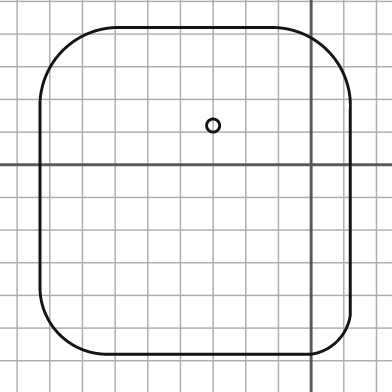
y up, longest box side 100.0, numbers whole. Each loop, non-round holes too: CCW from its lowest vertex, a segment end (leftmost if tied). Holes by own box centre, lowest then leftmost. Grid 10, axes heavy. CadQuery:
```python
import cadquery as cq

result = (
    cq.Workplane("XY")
    .moveTo(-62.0, -58.0)
    .lineTo(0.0, -58.0)
    .threePointArc((8.0, -54.0), (12.0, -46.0))
    .lineTo(12.0, 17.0)
    .threePointArc((5.0, 35.0), (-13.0, 42.0))
    .lineTo(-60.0, 42.0)
    .threePointArc((-76.0, 35.0), (-83.0, 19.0))
    .lineTo(-83.0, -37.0)
    .threePointArc((-77.0, -52.0), (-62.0, -58.0))
    .close()
    .moveTo(-30.0, 12.0)
    .circle(2.0)
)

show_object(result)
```